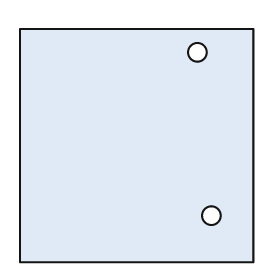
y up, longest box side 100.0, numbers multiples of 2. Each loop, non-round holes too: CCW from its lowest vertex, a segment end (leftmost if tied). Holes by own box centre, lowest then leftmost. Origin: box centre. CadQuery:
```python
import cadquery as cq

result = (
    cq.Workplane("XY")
    .moveTo(-50.0, -50.0)
    .lineTo(50.0, -50.0)
    .lineTo(50.0, 50.0)
    .lineTo(-50.0, 50.0)
    .close()
    .moveTo(32.0, -30.0)
    .circle(4.0)
    .moveTo(26.0, 40.0)
    .circle(4.0)
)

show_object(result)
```